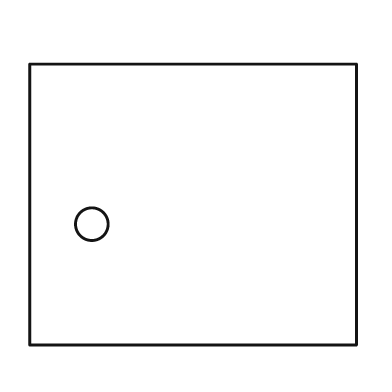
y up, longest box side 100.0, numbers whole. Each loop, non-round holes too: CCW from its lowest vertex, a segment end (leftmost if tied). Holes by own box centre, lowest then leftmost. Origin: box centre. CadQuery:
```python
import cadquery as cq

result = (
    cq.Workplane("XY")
    .moveTo(-50.0, -43.0)
    .lineTo(50.0, -43.0)
    .lineTo(50.0, 43.0)
    .lineTo(-50.0, 43.0)
    .close()
    .moveTo(-31.0, -6.0)
    .circle(5.0)
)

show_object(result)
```